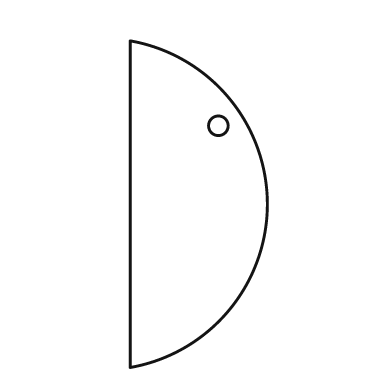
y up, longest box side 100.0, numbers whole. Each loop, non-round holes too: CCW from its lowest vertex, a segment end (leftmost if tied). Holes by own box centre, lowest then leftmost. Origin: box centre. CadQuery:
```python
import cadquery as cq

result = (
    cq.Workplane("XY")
    .moveTo(-21.0, -50.0)
    .threePointArc((21.0, 0.0), (-21.0, 50.0))
    .close()
    .moveTo(6.0, 24.0)
    .circle(3.0)
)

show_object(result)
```